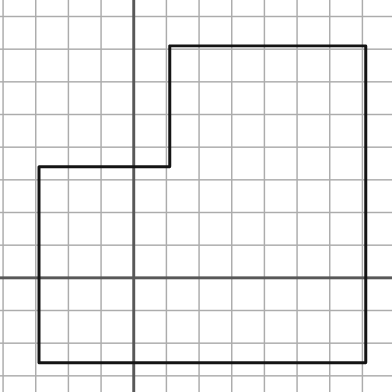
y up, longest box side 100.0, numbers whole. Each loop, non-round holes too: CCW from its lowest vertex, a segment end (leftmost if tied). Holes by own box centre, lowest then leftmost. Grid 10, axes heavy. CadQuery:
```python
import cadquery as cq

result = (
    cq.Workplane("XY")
    .moveTo(-29.0, -26.0)
    .lineTo(71.0, -26.0)
    .lineTo(71.0, 71.0)
    .lineTo(11.0, 71.0)
    .lineTo(11.0, 34.0)
    .lineTo(-29.0, 34.0)
    .close()
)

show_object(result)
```